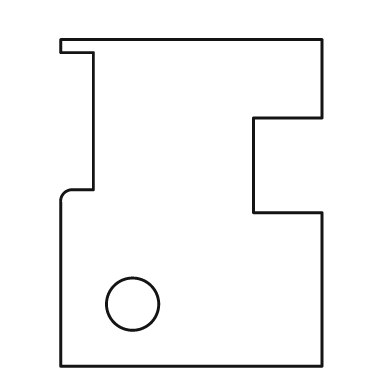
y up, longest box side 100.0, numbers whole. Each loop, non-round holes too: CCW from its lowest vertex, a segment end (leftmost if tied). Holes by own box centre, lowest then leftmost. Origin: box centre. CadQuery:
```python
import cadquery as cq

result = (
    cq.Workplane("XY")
    .moveTo(-40.0, -50.0)
    .lineTo(40.0, -50.0)
    .lineTo(40.0, -3.0)
    .lineTo(19.0, -3.0)
    .lineTo(19.0, 26.0)
    .lineTo(40.0, 26.0)
    .lineTo(40.0, 50.0)
    .lineTo(-40.0, 50.0)
    .lineTo(-40.0, 46.0)
    .lineTo(-30.0, 46.0)
    .lineTo(-30.0, 4.0)
    .lineTo(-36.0, 4.0)
    .threePointArc((-39.0, 3.0), (-40.0, 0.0))
    .close()
    .moveTo(-18.0, -31.0)
    .circle(8.0)
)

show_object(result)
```